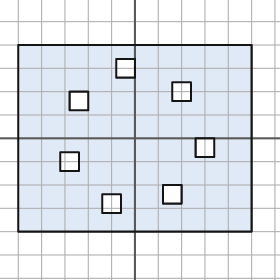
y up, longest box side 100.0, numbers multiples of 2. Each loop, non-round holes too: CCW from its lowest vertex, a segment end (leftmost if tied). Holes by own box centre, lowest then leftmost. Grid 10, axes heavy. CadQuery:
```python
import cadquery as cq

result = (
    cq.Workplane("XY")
    .moveTo(-50.0, -40.0)
    .lineTo(50.0, -40.0)
    .lineTo(50.0, 40.0)
    .lineTo(-50.0, 40.0)
    .close()
    .moveTo(-14.0, -32.0)
    .lineTo(-6.0, -32.0)
    .lineTo(-6.0, -24.0)
    .lineTo(-14.0, -24.0)
    .close()
    .moveTo(12.0, -28.0)
    .lineTo(20.0, -28.0)
    .lineTo(20.0, -20.0)
    .lineTo(12.0, -20.0)
    .close()
    .moveTo(-32.0, -14.0)
    .lineTo(-24.0, -14.0)
    .lineTo(-24.0, -6.0)
    .lineTo(-32.0, -6.0)
    .close()
    .moveTo(26.0, -8.0)
    .lineTo(34.0, -8.0)
    .lineTo(34.0, 0.0)
    .lineTo(26.0, 0.0)
    .close()
    .moveTo(-28.0, 12.0)
    .lineTo(-20.0, 12.0)
    .lineTo(-20.0, 20.0)
    .lineTo(-28.0, 20.0)
    .close()
    .moveTo(16.0, 16.0)
    .lineTo(24.0, 16.0)
    .lineTo(24.0, 24.0)
    .lineTo(16.0, 24.0)
    .close()
    .moveTo(-8.0, 26.0)
    .lineTo(0.0, 26.0)
    .lineTo(0.0, 34.0)
    .lineTo(-8.0, 34.0)
    .close()
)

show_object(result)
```